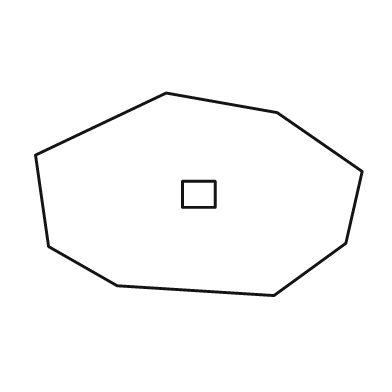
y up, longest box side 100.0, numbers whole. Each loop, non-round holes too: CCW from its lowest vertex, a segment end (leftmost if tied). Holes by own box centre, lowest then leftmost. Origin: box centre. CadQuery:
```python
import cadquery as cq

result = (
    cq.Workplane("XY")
    .moveTo(23.0, -31.0)
    .lineTo(45.0, -15.0)
    .lineTo(50.0, 7.0)
    .lineTo(24.0, 25.0)
    .lineTo(-10.0, 31.0)
    .lineTo(-50.0, 12.0)
    .lineTo(-46.0, -16.0)
    .lineTo(-25.0, -28.0)
    .close()
    .moveTo(-5.0, -4.0)
    .lineTo(5.0, -4.0)
    .lineTo(5.0, 4.0)
    .lineTo(-5.0, 4.0)
    .close()
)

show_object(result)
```